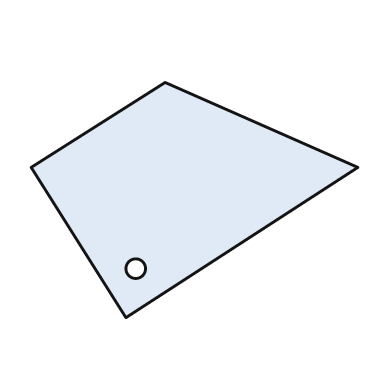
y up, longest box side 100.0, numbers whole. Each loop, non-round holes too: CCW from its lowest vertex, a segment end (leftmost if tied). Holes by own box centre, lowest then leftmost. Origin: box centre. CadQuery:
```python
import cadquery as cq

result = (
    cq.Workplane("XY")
    .moveTo(-21.0, -36.0)
    .lineTo(50.0, 10.0)
    .lineTo(-9.0, 36.0)
    .lineTo(-50.0, 10.0)
    .close()
    .moveTo(-18.0, -21.0)
    .circle(3.0)
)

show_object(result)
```